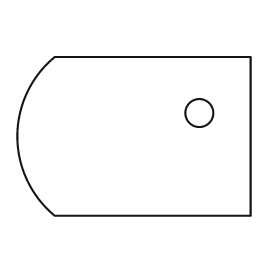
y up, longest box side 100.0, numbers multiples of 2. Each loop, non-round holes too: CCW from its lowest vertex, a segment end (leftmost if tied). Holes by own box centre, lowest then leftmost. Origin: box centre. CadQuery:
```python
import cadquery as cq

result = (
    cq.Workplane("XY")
    .moveTo(-34.0, -34.0)
    .lineTo(50.0, -34.0)
    .lineTo(50.0, 34.0)
    .lineTo(-34.0, 34.0)
    .threePointArc((-50.0, 0.0), (-34.0, -34.0))
    .close()
    .moveTo(28.0, 10.0)
    .circle(6.0)
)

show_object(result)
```